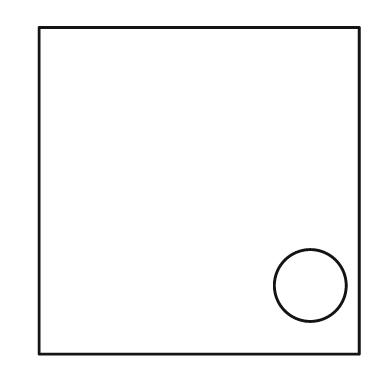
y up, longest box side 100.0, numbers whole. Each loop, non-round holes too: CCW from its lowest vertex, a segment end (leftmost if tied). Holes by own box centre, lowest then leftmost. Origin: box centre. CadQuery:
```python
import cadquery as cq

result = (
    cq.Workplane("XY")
    .moveTo(-49.0, -50.0)
    .lineTo(49.0, -50.0)
    .lineTo(49.0, 50.0)
    .lineTo(-49.0, 50.0)
    .close()
    .moveTo(34.0, -29.0)
    .circle(11.0)
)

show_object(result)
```